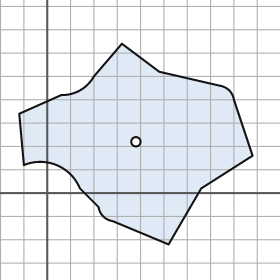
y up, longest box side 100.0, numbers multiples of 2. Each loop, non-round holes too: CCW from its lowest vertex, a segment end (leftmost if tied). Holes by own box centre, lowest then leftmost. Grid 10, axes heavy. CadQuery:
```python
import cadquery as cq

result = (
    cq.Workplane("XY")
    .moveTo(52.0, -22.0)
    .lineTo(66.0, 2.0)
    .lineTo(88.0, 16.0)
    .lineTo(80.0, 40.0)
    .threePointArc((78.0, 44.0), (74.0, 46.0))
    .lineTo(48.0, 52.0)
    .lineTo(32.0, 64.0)
    .lineTo(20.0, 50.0)
    .threePointArc((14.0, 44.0), (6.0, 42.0))
    .lineTo(-12.0, 34.0)
    .lineTo(-10.0, 12.0)
    .threePointArc((4.0, 12.0), (14.0, 2.0))
    .lineTo(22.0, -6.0)
    .threePointArc((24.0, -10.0), (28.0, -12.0))
    .close()
    .moveTo(38.0, 22.0)
    .circle(2.0)
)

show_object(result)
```